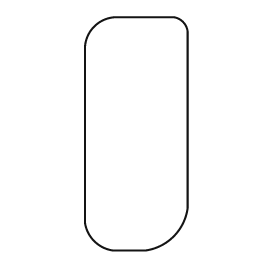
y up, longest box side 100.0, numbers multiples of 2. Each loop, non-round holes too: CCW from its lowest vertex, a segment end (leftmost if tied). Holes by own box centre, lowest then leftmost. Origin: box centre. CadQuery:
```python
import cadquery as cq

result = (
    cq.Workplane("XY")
    .moveTo(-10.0, -50.0)
    .lineTo(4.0, -50.0)
    .threePointArc((16.0, -44.0), (22.0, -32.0))
    .lineTo(22.0, 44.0)
    .threePointArc((20.0, 48.0), (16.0, 50.0))
    .lineTo(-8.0, 50.0)
    .threePointArc((-18.0, 46.0), (-22.0, 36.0))
    .lineTo(-22.0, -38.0)
    .threePointArc((-18.0, -46.0), (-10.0, -50.0))
    .close()
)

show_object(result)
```